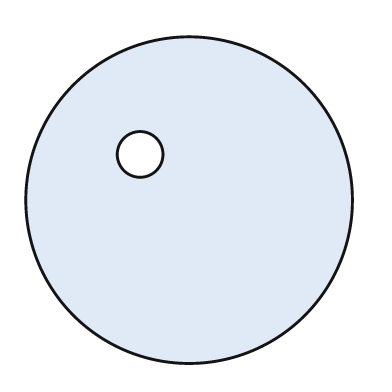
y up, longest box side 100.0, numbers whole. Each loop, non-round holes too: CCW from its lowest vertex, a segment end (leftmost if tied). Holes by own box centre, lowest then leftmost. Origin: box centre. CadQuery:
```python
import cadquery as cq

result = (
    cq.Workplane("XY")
    .moveTo(0.0, 0.0)
    .circle(50.0)
    .moveTo(-15.0, 14.0)
    .circle(7.0)
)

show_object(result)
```